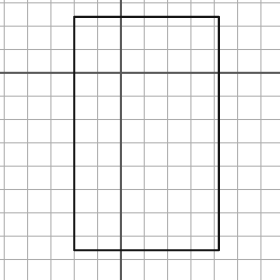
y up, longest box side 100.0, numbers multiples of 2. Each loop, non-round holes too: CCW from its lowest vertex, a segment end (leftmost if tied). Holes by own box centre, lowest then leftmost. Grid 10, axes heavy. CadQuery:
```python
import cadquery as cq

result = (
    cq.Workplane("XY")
    .moveTo(-20.0, -76.0)
    .lineTo(42.0, -76.0)
    .lineTo(42.0, 24.0)
    .lineTo(-20.0, 24.0)
    .close()
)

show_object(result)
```